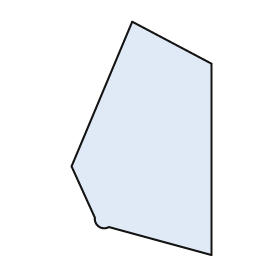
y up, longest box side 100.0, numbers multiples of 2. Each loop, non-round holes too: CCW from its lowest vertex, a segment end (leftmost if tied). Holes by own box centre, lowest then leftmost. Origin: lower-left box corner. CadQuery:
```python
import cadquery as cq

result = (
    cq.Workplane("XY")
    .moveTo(60.0, 0.0)
    .lineTo(60.0, 82.0)
    .lineTo(26.0, 100.0)
    .lineTo(0.0, 38.0)
    .lineTo(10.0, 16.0)
    .threePointArc((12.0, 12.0), (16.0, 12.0))
    .close()
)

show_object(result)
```